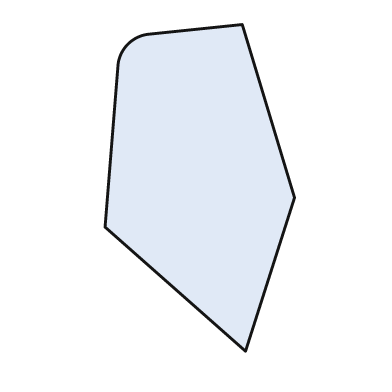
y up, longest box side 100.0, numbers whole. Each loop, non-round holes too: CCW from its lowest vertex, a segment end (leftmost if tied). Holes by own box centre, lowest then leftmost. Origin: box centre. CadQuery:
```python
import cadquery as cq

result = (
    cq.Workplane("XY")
    .moveTo(14.0, -50.0)
    .lineTo(29.0, -3.0)
    .lineTo(13.0, 50.0)
    .lineTo(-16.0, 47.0)
    .threePointArc((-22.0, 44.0), (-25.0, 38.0))
    .lineTo(-29.0, -12.0)
    .close()
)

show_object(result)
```